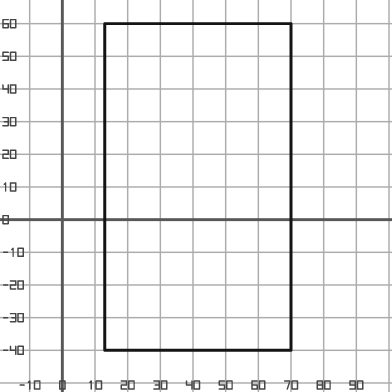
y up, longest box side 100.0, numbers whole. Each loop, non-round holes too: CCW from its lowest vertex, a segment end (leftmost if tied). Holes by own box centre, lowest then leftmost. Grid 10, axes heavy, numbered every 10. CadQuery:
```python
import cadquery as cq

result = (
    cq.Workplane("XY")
    .moveTo(13.0, -40.0)
    .lineTo(70.0, -40.0)
    .lineTo(70.0, 60.0)
    .lineTo(13.0, 60.0)
    .close()
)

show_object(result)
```